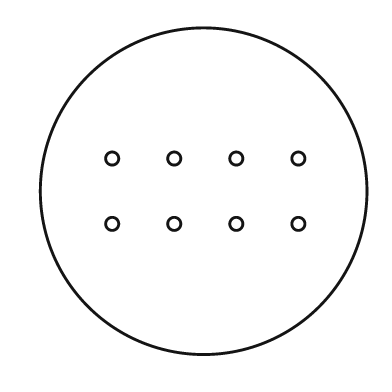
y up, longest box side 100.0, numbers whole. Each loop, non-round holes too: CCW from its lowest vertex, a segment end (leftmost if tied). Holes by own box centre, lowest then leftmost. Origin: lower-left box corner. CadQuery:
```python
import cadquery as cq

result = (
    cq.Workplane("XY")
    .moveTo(50.0, 50.0)
    .circle(50.0)
    .moveTo(22.0, 40.0)
    .circle(2.0)
    .moveTo(41.0, 40.0)
    .circle(2.0)
    .moveTo(60.0, 40.0)
    .circle(2.0)
    .moveTo(79.0, 40.0)
    .circle(2.0)
    .moveTo(22.0, 60.0)
    .circle(2.0)
    .moveTo(41.0, 60.0)
    .circle(2.0)
    .moveTo(60.0, 60.0)
    .circle(2.0)
    .moveTo(79.0, 60.0)
    .circle(2.0)
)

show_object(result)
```